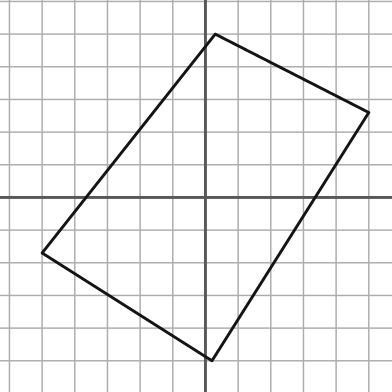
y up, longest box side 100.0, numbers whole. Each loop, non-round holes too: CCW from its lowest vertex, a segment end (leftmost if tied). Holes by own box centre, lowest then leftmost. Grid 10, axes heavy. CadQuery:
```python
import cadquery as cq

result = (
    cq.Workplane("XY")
    .moveTo(2.0, -50.0)
    .lineTo(50.0, 26.0)
    .lineTo(3.0, 50.0)
    .lineTo(-50.0, -17.0)
    .close()
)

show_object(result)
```